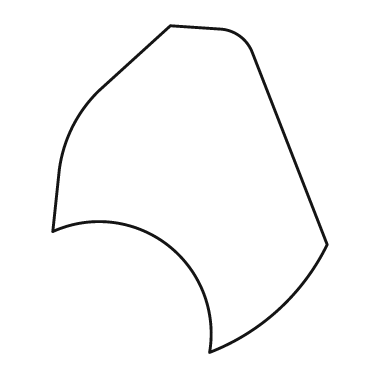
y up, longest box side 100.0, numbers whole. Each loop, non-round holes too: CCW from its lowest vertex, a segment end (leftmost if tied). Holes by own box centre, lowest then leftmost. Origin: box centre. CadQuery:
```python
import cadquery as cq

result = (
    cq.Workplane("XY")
    .moveTo(6.0, -50.0)
    .threePointArc((27.0, -37.0), (42.0, -17.0))
    .lineTo(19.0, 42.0)
    .threePointArc((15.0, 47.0), (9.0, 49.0))
    .lineTo(-6.0, 50.0)
    .lineTo(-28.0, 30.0)
    .threePointArc((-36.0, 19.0), (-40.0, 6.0))
    .lineTo(-42.0, -13.0)
    .threePointArc((-7.0, -17.0), (6.0, -50.0))
    .close()
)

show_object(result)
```